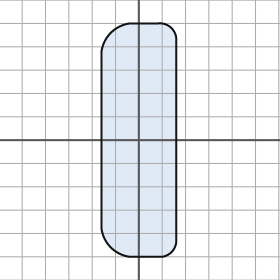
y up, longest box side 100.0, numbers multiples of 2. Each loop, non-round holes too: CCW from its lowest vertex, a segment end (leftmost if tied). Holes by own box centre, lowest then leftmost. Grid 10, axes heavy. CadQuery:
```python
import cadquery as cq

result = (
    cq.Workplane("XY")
    .moveTo(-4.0, -50.0)
    .lineTo(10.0, -50.0)
    .threePointArc((14.0, -48.0), (16.0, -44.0))
    .lineTo(16.0, 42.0)
    .threePointArc((14.0, 48.0), (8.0, 50.0))
    .lineTo(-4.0, 50.0)
    .threePointArc((-12.0, 46.0), (-16.0, 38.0))
    .lineTo(-16.0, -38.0)
    .threePointArc((-12.0, -46.0), (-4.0, -50.0))
    .close()
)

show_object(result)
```